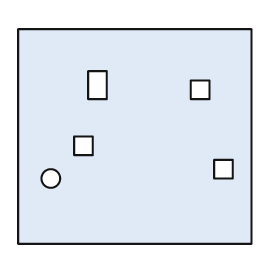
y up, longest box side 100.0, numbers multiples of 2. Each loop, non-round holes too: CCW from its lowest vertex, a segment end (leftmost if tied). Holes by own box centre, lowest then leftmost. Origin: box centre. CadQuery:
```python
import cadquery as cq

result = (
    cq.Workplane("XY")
    .moveTo(-50.0, -46.0)
    .lineTo(50.0, -46.0)
    .lineTo(50.0, 46.0)
    .lineTo(-50.0, 46.0)
    .close()
    .moveTo(-36.0, -18.0)
    .circle(4.0)
    .moveTo(34.0, -18.0)
    .lineTo(42.0, -18.0)
    .lineTo(42.0, -10.0)
    .lineTo(34.0, -10.0)
    .close()
    .moveTo(-26.0, -8.0)
    .lineTo(-18.0, -8.0)
    .lineTo(-18.0, 0.0)
    .lineTo(-26.0, 0.0)
    .close()
    .moveTo(24.0, 16.0)
    .lineTo(32.0, 16.0)
    .lineTo(32.0, 24.0)
    .lineTo(24.0, 24.0)
    .close()
    .moveTo(-20.0, 16.0)
    .lineTo(-12.0, 16.0)
    .lineTo(-12.0, 28.0)
    .lineTo(-20.0, 28.0)
    .close()
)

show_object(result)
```